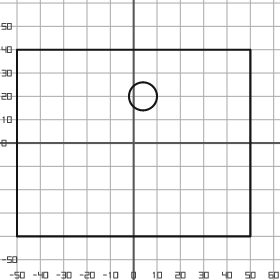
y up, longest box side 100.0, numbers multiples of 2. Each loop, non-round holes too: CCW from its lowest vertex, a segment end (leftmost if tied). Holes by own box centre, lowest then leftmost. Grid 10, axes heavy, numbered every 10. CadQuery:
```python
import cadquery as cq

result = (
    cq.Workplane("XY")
    .moveTo(-50.0, -40.0)
    .lineTo(50.0, -40.0)
    .lineTo(50.0, 40.0)
    .lineTo(-50.0, 40.0)
    .close()
    .moveTo(4.0, 20.0)
    .circle(6.0)
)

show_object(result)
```